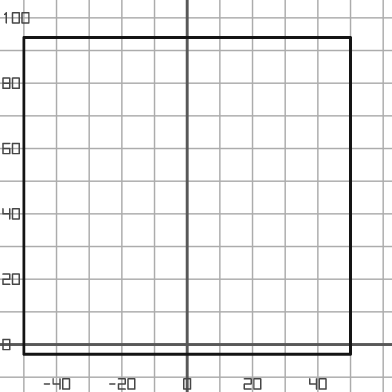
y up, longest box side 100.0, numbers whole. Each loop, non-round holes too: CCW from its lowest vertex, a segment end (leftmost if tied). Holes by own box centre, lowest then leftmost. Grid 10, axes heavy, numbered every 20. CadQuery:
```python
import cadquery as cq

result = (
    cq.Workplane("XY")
    .moveTo(-50.0, -3.0)
    .lineTo(50.0, -3.0)
    .lineTo(50.0, 94.0)
    .lineTo(-50.0, 94.0)
    .close()
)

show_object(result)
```